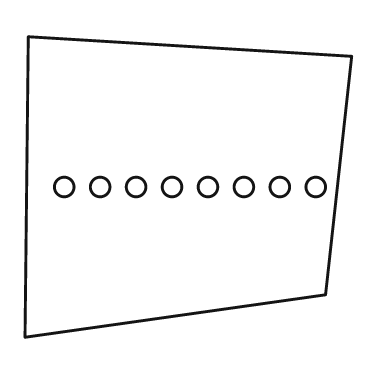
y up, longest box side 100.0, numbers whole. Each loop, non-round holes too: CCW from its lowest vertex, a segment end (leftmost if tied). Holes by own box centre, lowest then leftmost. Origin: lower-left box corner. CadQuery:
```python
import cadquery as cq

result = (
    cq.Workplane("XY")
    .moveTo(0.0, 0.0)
    .lineTo(92.0, 13.0)
    .lineTo(100.0, 86.0)
    .lineTo(1.0, 92.0)
    .close()
    .moveTo(12.0, 46.0)
    .circle(3.0)
    .moveTo(23.0, 46.0)
    .circle(3.0)
    .moveTo(34.0, 46.0)
    .circle(3.0)
    .moveTo(45.0, 46.0)
    .circle(3.0)
    .moveTo(56.0, 46.0)
    .circle(3.0)
    .moveTo(67.0, 46.0)
    .circle(3.0)
    .moveTo(78.0, 46.0)
    .circle(3.0)
    .moveTo(89.0, 46.0)
    .circle(3.0)
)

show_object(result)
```